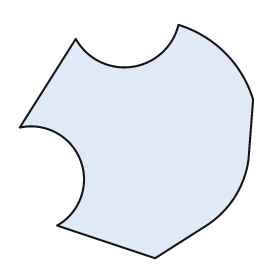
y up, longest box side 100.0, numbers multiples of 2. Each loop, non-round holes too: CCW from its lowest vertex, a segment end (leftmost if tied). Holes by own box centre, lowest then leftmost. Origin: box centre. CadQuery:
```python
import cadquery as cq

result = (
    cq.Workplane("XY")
    .moveTo(8.0, -50.0)
    .lineTo(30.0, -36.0)
    .threePointArc((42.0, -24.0), (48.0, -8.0))
    .lineTo(50.0, 18.0)
    .threePointArc((38.0, 38.0), (18.0, 50.0))
    .threePointArc((-2.0, 32.0), (-26.0, 44.0))
    .lineTo(-50.0, 6.0)
    .threePointArc((-24.0, -8.0), (-34.0, -36.0))
    .close()
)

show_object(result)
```